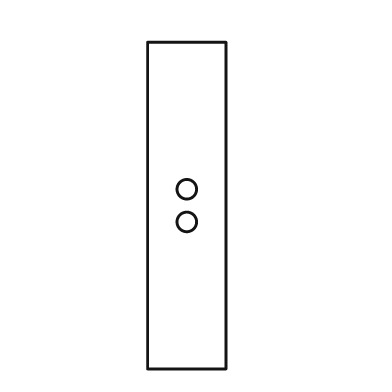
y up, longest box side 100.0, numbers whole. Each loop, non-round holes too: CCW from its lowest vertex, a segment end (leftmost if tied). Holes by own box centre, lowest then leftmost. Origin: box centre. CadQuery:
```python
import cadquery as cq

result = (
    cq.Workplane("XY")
    .moveTo(-12.0, -50.0)
    .lineTo(12.0, -50.0)
    .lineTo(12.0, 50.0)
    .lineTo(-12.0, 50.0)
    .close()
    .moveTo(0.0, -5.0)
    .circle(3.0)
    .moveTo(0.0, 5.0)
    .circle(3.0)
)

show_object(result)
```